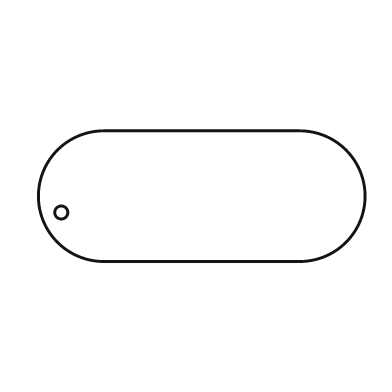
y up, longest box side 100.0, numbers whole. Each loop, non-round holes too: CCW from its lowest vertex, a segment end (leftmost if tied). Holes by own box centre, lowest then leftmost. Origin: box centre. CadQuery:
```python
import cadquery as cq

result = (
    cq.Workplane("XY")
    .moveTo(-30.0, -20.0)
    .lineTo(30.0, -20.0)
    .threePointArc((50.0, 0.0), (30.0, 20.0))
    .lineTo(-30.0, 20.0)
    .threePointArc((-50.0, 0.0), (-30.0, -20.0))
    .close()
    .moveTo(-43.0, -5.0)
    .circle(2.0)
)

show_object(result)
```